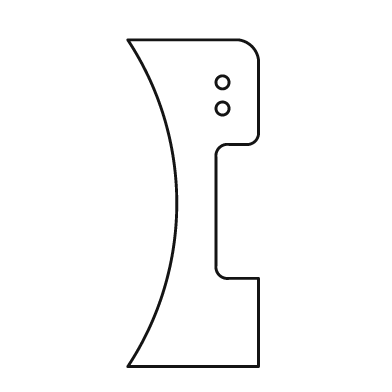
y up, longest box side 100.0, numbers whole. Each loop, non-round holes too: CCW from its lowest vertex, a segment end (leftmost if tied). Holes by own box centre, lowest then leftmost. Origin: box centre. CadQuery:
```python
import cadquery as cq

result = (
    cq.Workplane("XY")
    .moveTo(-20.0, -50.0)
    .lineTo(20.0, -50.0)
    .lineTo(20.0, -23.0)
    .lineTo(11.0, -23.0)
    .threePointArc((8.0, -22.0), (7.0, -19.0))
    .lineTo(7.0, 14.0)
    .threePointArc((8.0, 17.0), (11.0, 18.0))
    .lineTo(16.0, 18.0)
    .threePointArc((19.0, 19.0), (20.0, 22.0))
    .lineTo(20.0, 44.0)
    .threePointArc((18.0, 48.0), (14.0, 50.0))
    .lineTo(-20.0, 50.0)
    .threePointArc((-5.0, 0.0), (-20.0, -50.0))
    .close()
    .moveTo(9.0, 29.0)
    .circle(2.0)
    .moveTo(9.0, 37.0)
    .circle(2.0)
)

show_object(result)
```